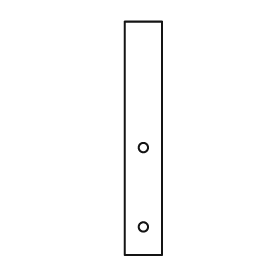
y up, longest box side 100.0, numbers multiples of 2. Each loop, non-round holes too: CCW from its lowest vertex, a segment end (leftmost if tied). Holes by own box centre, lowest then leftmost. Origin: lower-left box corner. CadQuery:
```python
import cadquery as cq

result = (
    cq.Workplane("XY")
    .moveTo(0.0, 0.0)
    .lineTo(16.0, 0.0)
    .lineTo(16.0, 100.0)
    .lineTo(0.0, 100.0)
    .close()
    .moveTo(8.0, 12.0)
    .circle(2.0)
    .moveTo(8.0, 46.0)
    .circle(2.0)
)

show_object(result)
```